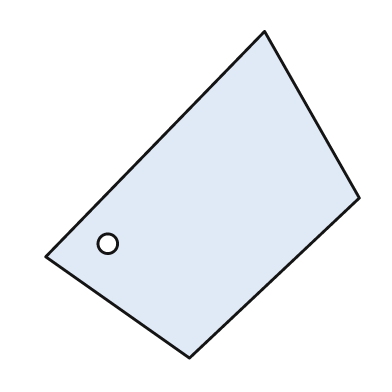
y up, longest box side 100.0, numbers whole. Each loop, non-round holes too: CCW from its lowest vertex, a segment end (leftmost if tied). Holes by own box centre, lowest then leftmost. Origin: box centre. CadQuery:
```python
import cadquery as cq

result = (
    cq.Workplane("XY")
    .moveTo(-4.0, -50.0)
    .lineTo(48.0, -1.0)
    .lineTo(19.0, 50.0)
    .lineTo(-48.0, -19.0)
    .close()
    .moveTo(-29.0, -15.0)
    .circle(3.0)
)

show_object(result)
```